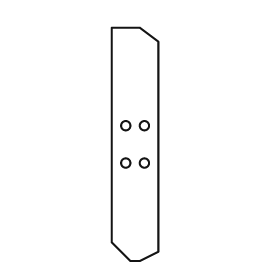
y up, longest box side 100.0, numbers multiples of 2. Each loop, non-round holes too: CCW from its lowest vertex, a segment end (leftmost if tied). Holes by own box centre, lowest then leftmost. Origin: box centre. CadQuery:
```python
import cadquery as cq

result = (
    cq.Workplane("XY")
    .moveTo(-2.0, -50.0)
    .lineTo(2.0, -50.0)
    .lineTo(10.0, -46.0)
    .lineTo(10.0, 44.0)
    .lineTo(2.0, 50.0)
    .lineTo(-10.0, 50.0)
    .lineTo(-10.0, -42.0)
    .close()
    .moveTo(-4.0, -8.0)
    .circle(2.0)
    .moveTo(4.0, -8.0)
    .circle(2.0)
    .moveTo(-4.0, 8.0)
    .circle(2.0)
    .moveTo(4.0, 8.0)
    .circle(2.0)
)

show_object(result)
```